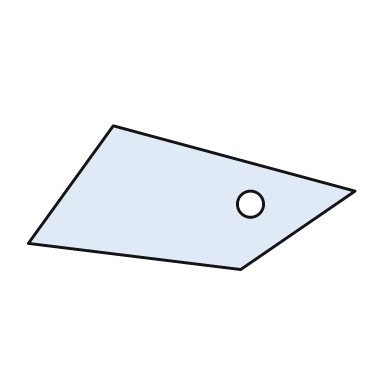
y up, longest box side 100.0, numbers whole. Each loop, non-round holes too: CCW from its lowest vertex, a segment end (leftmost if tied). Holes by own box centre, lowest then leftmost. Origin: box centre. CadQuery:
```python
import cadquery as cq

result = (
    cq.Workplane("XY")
    .moveTo(15.0, -22.0)
    .lineTo(50.0, 2.0)
    .lineTo(-24.0, 22.0)
    .lineTo(-50.0, -14.0)
    .close()
    .moveTo(18.0, -2.0)
    .circle(4.0)
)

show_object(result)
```